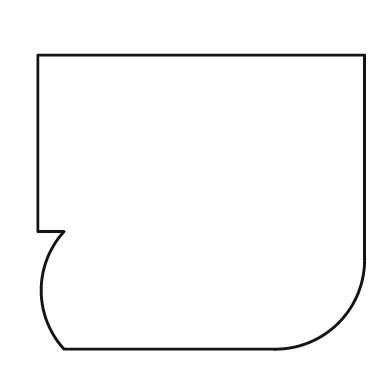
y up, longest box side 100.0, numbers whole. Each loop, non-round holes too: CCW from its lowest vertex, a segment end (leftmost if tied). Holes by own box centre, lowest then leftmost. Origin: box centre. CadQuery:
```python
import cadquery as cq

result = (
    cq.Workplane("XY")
    .moveTo(-42.0, -45.0)
    .lineTo(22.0, -45.0)
    .threePointArc((42.0, -37.0), (50.0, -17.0))
    .lineTo(50.0, 45.0)
    .lineTo(-50.0, 45.0)
    .lineTo(-50.0, -9.0)
    .lineTo(-42.0, -9.0)
    .threePointArc((-49.0, -27.0), (-42.0, -45.0))
    .close()
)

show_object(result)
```